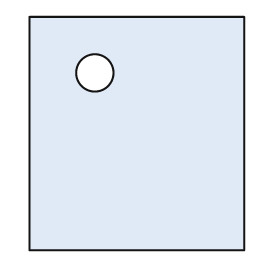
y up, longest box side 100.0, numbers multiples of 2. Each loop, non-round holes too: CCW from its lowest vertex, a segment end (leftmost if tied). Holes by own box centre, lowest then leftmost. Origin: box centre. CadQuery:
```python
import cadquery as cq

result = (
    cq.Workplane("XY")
    .moveTo(-46.0, -50.0)
    .lineTo(46.0, -50.0)
    .lineTo(46.0, 50.0)
    .lineTo(-46.0, 50.0)
    .close()
    .moveTo(-18.0, 26.0)
    .circle(8.0)
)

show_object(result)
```